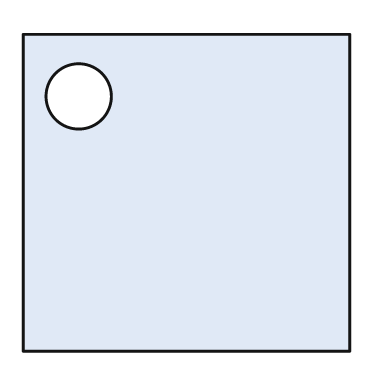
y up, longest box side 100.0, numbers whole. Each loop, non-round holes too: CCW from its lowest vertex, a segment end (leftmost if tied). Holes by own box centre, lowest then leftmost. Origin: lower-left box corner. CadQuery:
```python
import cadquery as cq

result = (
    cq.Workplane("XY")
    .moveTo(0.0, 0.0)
    .lineTo(100.0, 0.0)
    .lineTo(100.0, 97.0)
    .lineTo(0.0, 97.0)
    .close()
    .moveTo(17.0, 78.0)
    .circle(10.0)
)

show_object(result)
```